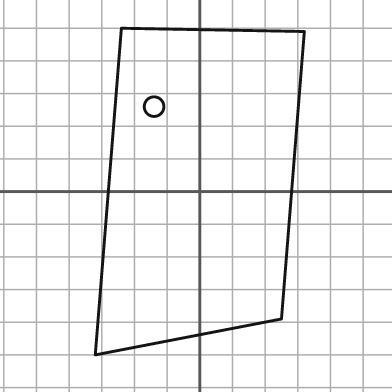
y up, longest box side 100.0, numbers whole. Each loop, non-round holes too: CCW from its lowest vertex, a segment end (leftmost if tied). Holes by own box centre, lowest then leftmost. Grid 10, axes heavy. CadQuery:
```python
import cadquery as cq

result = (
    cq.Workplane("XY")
    .moveTo(-32.0, -50.0)
    .lineTo(25.0, -39.0)
    .lineTo(32.0, 49.0)
    .lineTo(-24.0, 50.0)
    .close()
    .moveTo(-14.0, 26.0)
    .circle(3.0)
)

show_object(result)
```